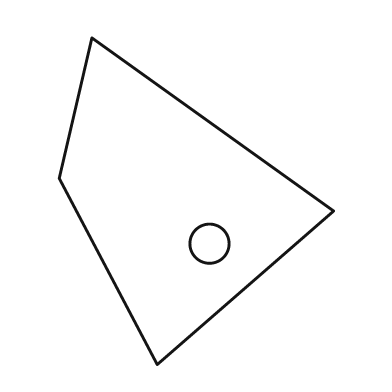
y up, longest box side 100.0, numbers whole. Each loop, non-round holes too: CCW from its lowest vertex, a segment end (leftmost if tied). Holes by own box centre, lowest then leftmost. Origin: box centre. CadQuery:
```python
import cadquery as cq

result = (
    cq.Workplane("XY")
    .moveTo(-12.0, -50.0)
    .lineTo(42.0, -3.0)
    .lineTo(-32.0, 50.0)
    .lineTo(-42.0, 7.0)
    .close()
    .moveTo(4.0, -13.0)
    .circle(6.0)
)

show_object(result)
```